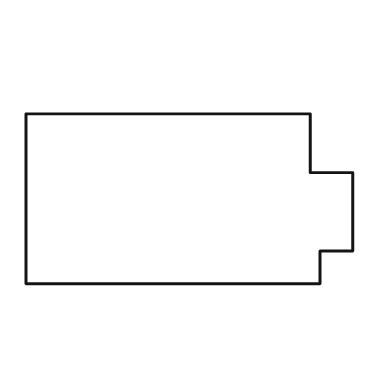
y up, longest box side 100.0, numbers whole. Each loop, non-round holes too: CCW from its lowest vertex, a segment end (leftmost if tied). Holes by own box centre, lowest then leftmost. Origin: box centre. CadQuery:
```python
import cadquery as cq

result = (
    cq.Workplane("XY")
    .moveTo(-50.0, -26.0)
    .lineTo(40.0, -26.0)
    .lineTo(40.0, -16.0)
    .lineTo(50.0, -16.0)
    .lineTo(50.0, 8.0)
    .lineTo(37.0, 8.0)
    .lineTo(37.0, 26.0)
    .lineTo(-50.0, 26.0)
    .close()
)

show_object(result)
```